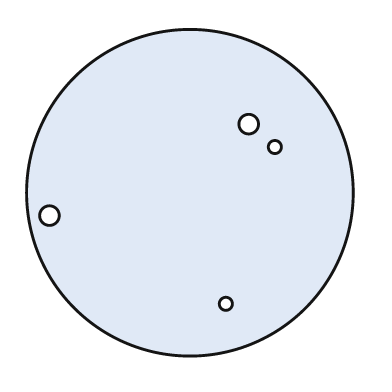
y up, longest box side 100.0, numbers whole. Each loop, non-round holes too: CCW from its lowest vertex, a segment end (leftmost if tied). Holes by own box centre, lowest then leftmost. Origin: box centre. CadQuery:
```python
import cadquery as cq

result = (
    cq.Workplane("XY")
    .moveTo(0.0, 0.0)
    .circle(50.0)
    .moveTo(11.0, -34.0)
    .circle(2.0)
    .moveTo(-43.0, -7.0)
    .circle(3.0)
    .moveTo(26.0, 14.0)
    .circle(2.0)
    .moveTo(18.0, 21.0)
    .circle(3.0)
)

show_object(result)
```